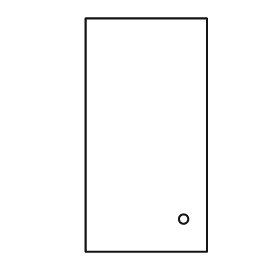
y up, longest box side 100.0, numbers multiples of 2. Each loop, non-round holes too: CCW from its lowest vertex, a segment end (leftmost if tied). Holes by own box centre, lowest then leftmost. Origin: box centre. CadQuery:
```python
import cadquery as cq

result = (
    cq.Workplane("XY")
    .moveTo(-26.0, -50.0)
    .lineTo(26.0, -50.0)
    .lineTo(26.0, 50.0)
    .lineTo(-26.0, 50.0)
    .close()
    .moveTo(16.0, -36.0)
    .circle(2.0)
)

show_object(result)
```